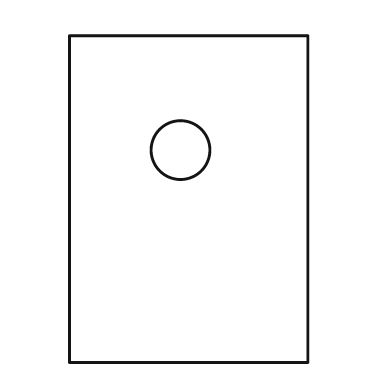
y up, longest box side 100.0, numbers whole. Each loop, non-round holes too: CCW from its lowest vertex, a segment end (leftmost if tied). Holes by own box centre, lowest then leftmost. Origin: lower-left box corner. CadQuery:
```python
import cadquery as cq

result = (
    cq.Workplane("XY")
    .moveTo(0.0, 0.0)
    .lineTo(73.0, 0.0)
    .lineTo(73.0, 100.0)
    .lineTo(0.0, 100.0)
    .close()
    .moveTo(34.0, 65.0)
    .circle(9.0)
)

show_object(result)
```